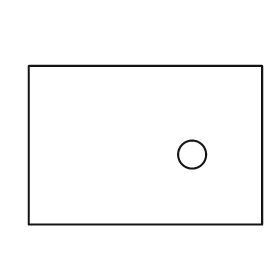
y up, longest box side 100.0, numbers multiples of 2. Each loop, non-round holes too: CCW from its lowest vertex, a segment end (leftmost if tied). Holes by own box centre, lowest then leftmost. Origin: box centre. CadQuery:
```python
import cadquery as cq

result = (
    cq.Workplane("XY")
    .moveTo(-50.0, -34.0)
    .lineTo(50.0, -34.0)
    .lineTo(50.0, 34.0)
    .lineTo(-50.0, 34.0)
    .close()
    .moveTo(20.0, -4.0)
    .circle(6.0)
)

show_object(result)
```